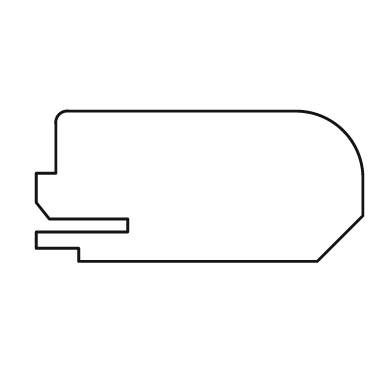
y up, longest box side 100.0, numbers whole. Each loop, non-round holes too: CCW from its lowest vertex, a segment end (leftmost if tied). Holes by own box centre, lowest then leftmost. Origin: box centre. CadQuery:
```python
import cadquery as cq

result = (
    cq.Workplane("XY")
    .moveTo(-37.0, -23.0)
    .lineTo(36.0, -23.0)
    .lineTo(50.0, -9.0)
    .lineTo(50.0, 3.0)
    .threePointArc((44.0, 17.0), (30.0, 23.0))
    .lineTo(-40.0, 23.0)
    .threePointArc((-43.0, 22.0), (-44.0, 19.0))
    .lineTo(-44.0, 4.0)
    .lineTo(-50.0, 4.0)
    .lineTo(-50.0, -5.0)
    .lineTo(-46.0, -10.0)
    .lineTo(-22.0, -10.0)
    .lineTo(-22.0, -14.0)
    .lineTo(-50.0, -14.0)
    .lineTo(-50.0, -19.0)
    .lineTo(-37.0, -19.0)
    .close()
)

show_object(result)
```